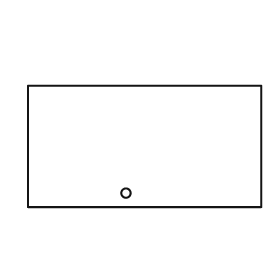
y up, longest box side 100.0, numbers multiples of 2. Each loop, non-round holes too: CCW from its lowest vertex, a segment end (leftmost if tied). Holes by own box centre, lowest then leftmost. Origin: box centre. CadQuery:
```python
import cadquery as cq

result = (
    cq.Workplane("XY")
    .moveTo(-50.0, -26.0)
    .lineTo(50.0, -26.0)
    .lineTo(50.0, 26.0)
    .lineTo(-50.0, 26.0)
    .close()
    .moveTo(-8.0, -20.0)
    .circle(2.0)
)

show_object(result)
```